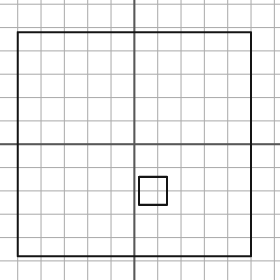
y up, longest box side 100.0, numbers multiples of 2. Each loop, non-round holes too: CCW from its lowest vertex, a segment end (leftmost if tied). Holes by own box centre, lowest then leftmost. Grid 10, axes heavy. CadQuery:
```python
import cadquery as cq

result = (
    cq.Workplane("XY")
    .moveTo(-50.0, -48.0)
    .lineTo(50.0, -48.0)
    .lineTo(50.0, 48.0)
    .lineTo(-50.0, 48.0)
    .close()
    .moveTo(2.0, -26.0)
    .lineTo(14.0, -26.0)
    .lineTo(14.0, -14.0)
    .lineTo(2.0, -14.0)
    .close()
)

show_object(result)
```